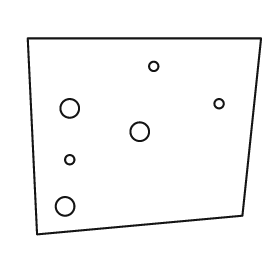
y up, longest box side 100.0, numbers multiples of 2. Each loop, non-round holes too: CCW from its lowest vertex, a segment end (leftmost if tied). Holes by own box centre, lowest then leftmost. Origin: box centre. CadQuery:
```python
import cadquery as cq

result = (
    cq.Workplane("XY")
    .moveTo(-46.0, -42.0)
    .lineTo(42.0, -34.0)
    .lineTo(50.0, 42.0)
    .lineTo(-50.0, 42.0)
    .close()
    .moveTo(-34.0, -30.0)
    .circle(4.0)
    .moveTo(-32.0, -10.0)
    .circle(2.0)
    .moveTo(-2.0, 2.0)
    .circle(4.0)
    .moveTo(-32.0, 12.0)
    .circle(4.0)
    .moveTo(32.0, 14.0)
    .circle(2.0)
    .moveTo(4.0, 30.0)
    .circle(2.0)
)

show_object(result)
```